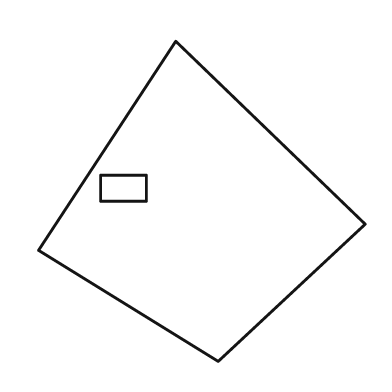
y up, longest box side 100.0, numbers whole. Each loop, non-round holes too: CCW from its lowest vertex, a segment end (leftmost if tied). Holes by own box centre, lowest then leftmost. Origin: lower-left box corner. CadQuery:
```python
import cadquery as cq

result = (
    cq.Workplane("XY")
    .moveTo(55.0, 0.0)
    .lineTo(100.0, 42.0)
    .lineTo(42.0, 98.0)
    .lineTo(0.0, 34.0)
    .close()
    .moveTo(19.0, 49.0)
    .lineTo(33.0, 49.0)
    .lineTo(33.0, 57.0)
    .lineTo(19.0, 57.0)
    .close()
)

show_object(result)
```